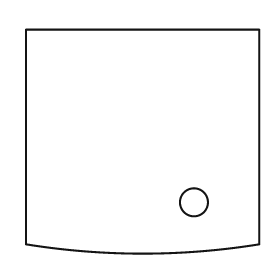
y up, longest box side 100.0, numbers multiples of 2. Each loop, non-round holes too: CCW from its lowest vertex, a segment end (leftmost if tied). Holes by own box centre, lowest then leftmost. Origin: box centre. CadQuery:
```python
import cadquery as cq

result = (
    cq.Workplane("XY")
    .moveTo(-50.0, -44.0)
    .threePointArc((0.0, -48.0), (50.0, -44.0))
    .lineTo(50.0, 48.0)
    .lineTo(-50.0, 48.0)
    .close()
    .moveTo(22.0, -26.0)
    .circle(6.0)
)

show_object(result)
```